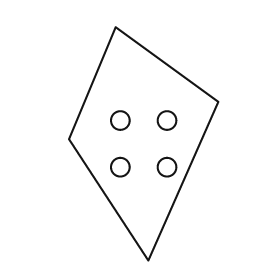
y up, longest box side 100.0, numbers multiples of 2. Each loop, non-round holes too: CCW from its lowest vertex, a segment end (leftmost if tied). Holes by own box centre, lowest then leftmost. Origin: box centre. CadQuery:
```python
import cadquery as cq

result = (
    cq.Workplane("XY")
    .moveTo(2.0, -50.0)
    .lineTo(32.0, 18.0)
    .lineTo(-12.0, 50.0)
    .lineTo(-32.0, 2.0)
    .close()
    .moveTo(-10.0, -10.0)
    .circle(4.0)
    .moveTo(10.0, -10.0)
    .circle(4.0)
    .moveTo(-10.0, 10.0)
    .circle(4.0)
    .moveTo(10.0, 10.0)
    .circle(4.0)
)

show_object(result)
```